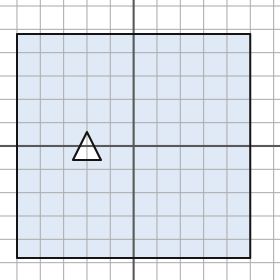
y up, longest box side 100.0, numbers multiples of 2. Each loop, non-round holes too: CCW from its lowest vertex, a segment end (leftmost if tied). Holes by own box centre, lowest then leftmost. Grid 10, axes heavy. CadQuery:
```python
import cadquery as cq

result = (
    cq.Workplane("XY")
    .moveTo(-50.0, -48.0)
    .lineTo(50.0, -48.0)
    .lineTo(50.0, 48.0)
    .lineTo(-50.0, 48.0)
    .close()
    .moveTo(-26.0, -6.0)
    .lineTo(-14.0, -6.0)
    .lineTo(-20.0, 6.0)
    .close()
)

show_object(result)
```